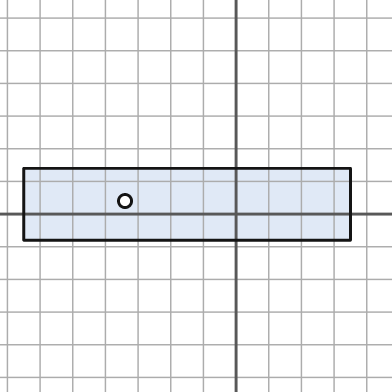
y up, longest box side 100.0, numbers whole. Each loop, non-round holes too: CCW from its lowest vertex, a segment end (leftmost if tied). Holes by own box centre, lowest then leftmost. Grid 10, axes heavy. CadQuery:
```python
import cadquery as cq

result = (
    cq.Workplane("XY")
    .moveTo(-65.0, -8.0)
    .lineTo(35.0, -8.0)
    .lineTo(35.0, 14.0)
    .lineTo(-65.0, 14.0)
    .close()
    .moveTo(-34.0, 4.0)
    .circle(2.0)
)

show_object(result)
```